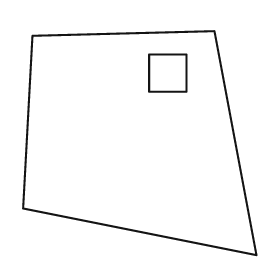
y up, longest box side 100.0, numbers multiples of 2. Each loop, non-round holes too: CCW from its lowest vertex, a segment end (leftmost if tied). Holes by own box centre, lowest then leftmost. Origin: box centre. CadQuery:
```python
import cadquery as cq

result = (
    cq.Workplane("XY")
    .moveTo(50.0, -48.0)
    .lineTo(32.0, 48.0)
    .lineTo(-46.0, 46.0)
    .lineTo(-50.0, -28.0)
    .close()
    .moveTo(4.0, 22.0)
    .lineTo(20.0, 22.0)
    .lineTo(20.0, 38.0)
    .lineTo(4.0, 38.0)
    .close()
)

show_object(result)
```